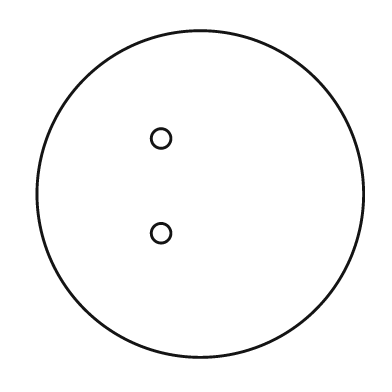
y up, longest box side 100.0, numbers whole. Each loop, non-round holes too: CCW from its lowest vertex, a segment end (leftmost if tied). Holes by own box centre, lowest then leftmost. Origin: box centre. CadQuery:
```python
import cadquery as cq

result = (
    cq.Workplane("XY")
    .moveTo(0.0, 0.0)
    .circle(50.0)
    .moveTo(-12.0, -12.0)
    .circle(3.0)
    .moveTo(-12.0, 17.0)
    .circle(3.0)
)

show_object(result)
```